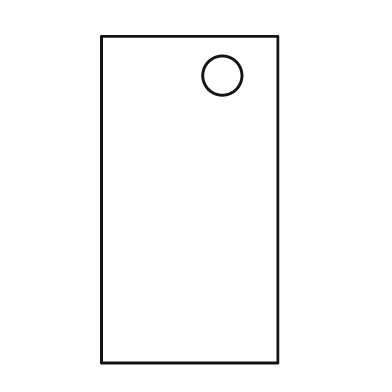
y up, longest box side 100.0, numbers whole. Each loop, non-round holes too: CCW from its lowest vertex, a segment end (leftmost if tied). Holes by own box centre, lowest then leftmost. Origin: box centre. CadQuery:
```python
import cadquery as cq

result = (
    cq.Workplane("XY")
    .moveTo(-27.0, -50.0)
    .lineTo(27.0, -50.0)
    .lineTo(27.0, 50.0)
    .lineTo(-27.0, 50.0)
    .close()
    .moveTo(10.0, 38.0)
    .circle(6.0)
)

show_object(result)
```